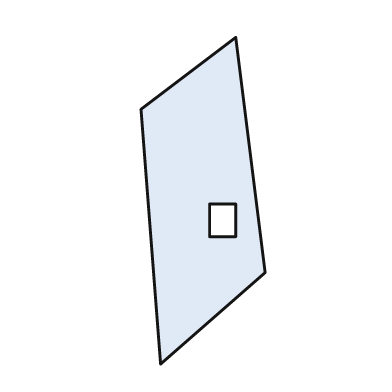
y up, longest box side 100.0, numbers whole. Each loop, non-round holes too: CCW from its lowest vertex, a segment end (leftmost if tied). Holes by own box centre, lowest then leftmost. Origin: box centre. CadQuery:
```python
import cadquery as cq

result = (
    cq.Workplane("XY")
    .moveTo(-13.0, -50.0)
    .lineTo(19.0, -22.0)
    .lineTo(10.0, 50.0)
    .lineTo(-19.0, 28.0)
    .close()
    .moveTo(2.0, -11.0)
    .lineTo(10.0, -11.0)
    .lineTo(10.0, -1.0)
    .lineTo(2.0, -1.0)
    .close()
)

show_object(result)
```